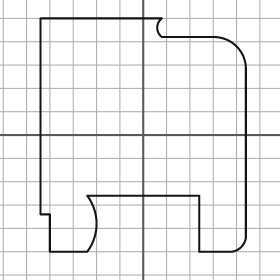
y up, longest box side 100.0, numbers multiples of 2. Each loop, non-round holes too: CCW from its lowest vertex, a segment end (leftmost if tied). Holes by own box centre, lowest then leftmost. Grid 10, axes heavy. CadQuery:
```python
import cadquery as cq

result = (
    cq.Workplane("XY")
    .moveTo(-40.0, -50.0)
    .lineTo(-24.0, -50.0)
    .threePointArc((-20.0, -38.0), (-24.0, -26.0))
    .lineTo(24.0, -26.0)
    .lineTo(24.0, -50.0)
    .lineTo(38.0, -50.0)
    .threePointArc((42.0, -48.0), (44.0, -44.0))
    .lineTo(44.0, 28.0)
    .threePointArc((40.0, 38.0), (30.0, 42.0))
    .lineTo(8.0, 42.0)
    .threePointArc((6.0, 46.0), (8.0, 50.0))
    .lineTo(-44.0, 50.0)
    .lineTo(-44.0, -34.0)
    .lineTo(-40.0, -34.0)
    .close()
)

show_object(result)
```